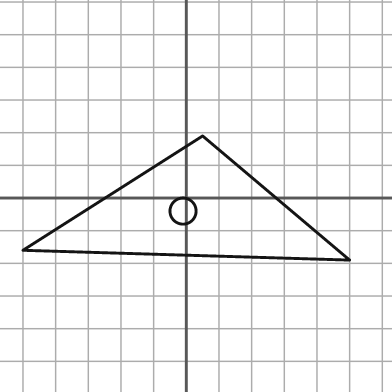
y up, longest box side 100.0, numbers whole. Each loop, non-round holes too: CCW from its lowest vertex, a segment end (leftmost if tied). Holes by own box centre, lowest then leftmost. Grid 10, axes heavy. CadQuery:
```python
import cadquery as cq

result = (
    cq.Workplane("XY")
    .moveTo(50.0, -19.0)
    .lineTo(5.0, 19.0)
    .lineTo(-50.0, -16.0)
    .close()
    .moveTo(-1.0, -4.0)
    .circle(4.0)
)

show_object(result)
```